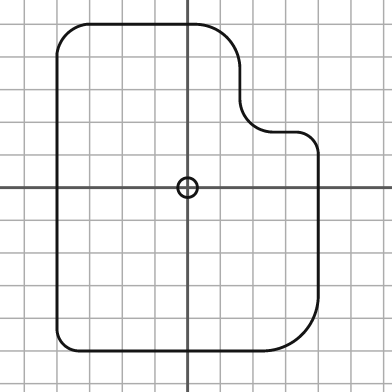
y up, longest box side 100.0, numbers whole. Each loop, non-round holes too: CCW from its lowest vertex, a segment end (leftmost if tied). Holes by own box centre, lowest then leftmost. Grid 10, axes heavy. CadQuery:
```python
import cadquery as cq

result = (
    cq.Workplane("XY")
    .moveTo(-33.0, -50.0)
    .lineTo(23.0, -50.0)
    .threePointArc((35.0, -45.0), (40.0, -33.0))
    .lineTo(40.0, 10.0)
    .threePointArc((38.0, 15.0), (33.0, 17.0))
    .lineTo(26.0, 17.0)
    .threePointArc((19.0, 20.0), (16.0, 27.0))
    .lineTo(16.0, 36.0)
    .threePointArc((12.0, 46.0), (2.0, 50.0))
    .lineTo(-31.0, 50.0)
    .threePointArc((-37.0, 47.0), (-40.0, 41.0))
    .lineTo(-40.0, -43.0)
    .threePointArc((-38.0, -48.0), (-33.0, -50.0))
    .close()
    .moveTo(0.0, 0.0)
    .circle(3.0)
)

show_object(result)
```